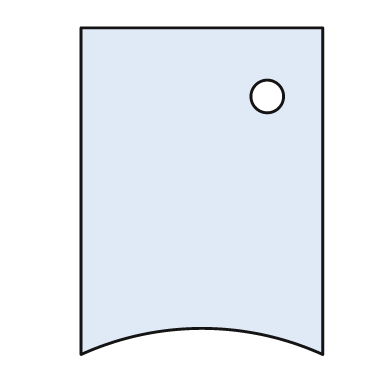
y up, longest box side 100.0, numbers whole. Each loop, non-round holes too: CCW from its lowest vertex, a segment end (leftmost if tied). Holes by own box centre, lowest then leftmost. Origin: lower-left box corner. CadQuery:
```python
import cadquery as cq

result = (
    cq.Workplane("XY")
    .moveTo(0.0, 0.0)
    .threePointArc((37.0, 8.0), (74.0, 0.0))
    .lineTo(74.0, 100.0)
    .lineTo(0.0, 100.0)
    .close()
    .moveTo(57.0, 79.0)
    .circle(5.0)
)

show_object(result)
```